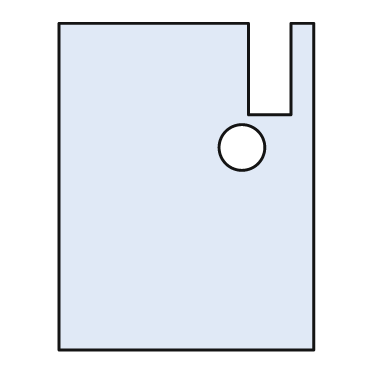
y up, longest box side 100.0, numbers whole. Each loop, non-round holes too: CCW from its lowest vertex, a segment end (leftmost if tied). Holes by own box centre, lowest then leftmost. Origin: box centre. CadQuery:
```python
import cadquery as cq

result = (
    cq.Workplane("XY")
    .moveTo(-39.0, -50.0)
    .lineTo(39.0, -50.0)
    .lineTo(39.0, 50.0)
    .lineTo(32.0, 50.0)
    .lineTo(32.0, 22.0)
    .lineTo(19.0, 22.0)
    .lineTo(19.0, 50.0)
    .lineTo(-39.0, 50.0)
    .close()
    .moveTo(17.0, 12.0)
    .circle(7.0)
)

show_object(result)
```